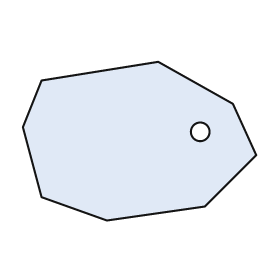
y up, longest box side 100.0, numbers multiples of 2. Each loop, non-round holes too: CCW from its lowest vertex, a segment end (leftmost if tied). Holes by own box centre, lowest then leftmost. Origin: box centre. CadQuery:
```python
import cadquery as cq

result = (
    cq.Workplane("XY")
    .moveTo(-14.0, -34.0)
    .lineTo(28.0, -28.0)
    .lineTo(50.0, -6.0)
    .lineTo(40.0, 16.0)
    .lineTo(8.0, 34.0)
    .lineTo(-42.0, 26.0)
    .lineTo(-50.0, 6.0)
    .lineTo(-42.0, -24.0)
    .close()
    .moveTo(26.0, 4.0)
    .circle(4.0)
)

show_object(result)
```